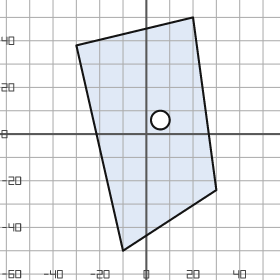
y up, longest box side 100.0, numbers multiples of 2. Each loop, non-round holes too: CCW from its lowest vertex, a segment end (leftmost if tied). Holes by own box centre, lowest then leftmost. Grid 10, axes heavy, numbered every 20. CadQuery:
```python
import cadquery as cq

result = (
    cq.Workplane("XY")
    .moveTo(-10.0, -50.0)
    .lineTo(30.0, -24.0)
    .lineTo(20.0, 50.0)
    .lineTo(-30.0, 38.0)
    .close()
    .moveTo(6.0, 6.0)
    .circle(4.0)
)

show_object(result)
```